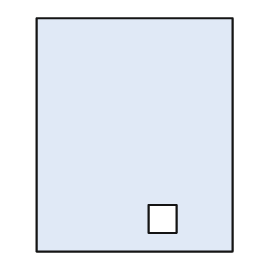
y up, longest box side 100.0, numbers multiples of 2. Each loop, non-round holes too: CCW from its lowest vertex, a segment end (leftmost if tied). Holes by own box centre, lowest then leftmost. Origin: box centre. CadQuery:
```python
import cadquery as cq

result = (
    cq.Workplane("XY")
    .moveTo(-42.0, -50.0)
    .lineTo(42.0, -50.0)
    .lineTo(42.0, 50.0)
    .lineTo(-42.0, 50.0)
    .close()
    .moveTo(6.0, -42.0)
    .lineTo(18.0, -42.0)
    .lineTo(18.0, -30.0)
    .lineTo(6.0, -30.0)
    .close()
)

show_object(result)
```